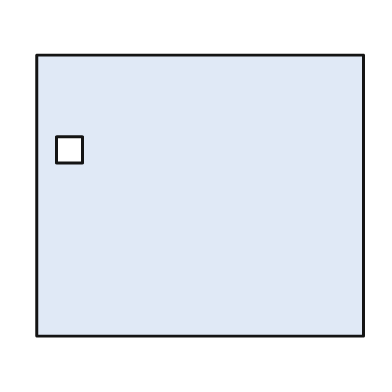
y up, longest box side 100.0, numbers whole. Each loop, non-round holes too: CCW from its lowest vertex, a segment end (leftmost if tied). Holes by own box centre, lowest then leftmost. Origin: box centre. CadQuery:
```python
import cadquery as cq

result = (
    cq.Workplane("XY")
    .moveTo(-50.0, -43.0)
    .lineTo(50.0, -43.0)
    .lineTo(50.0, 43.0)
    .lineTo(-50.0, 43.0)
    .close()
    .moveTo(-44.0, 10.0)
    .lineTo(-36.0, 10.0)
    .lineTo(-36.0, 18.0)
    .lineTo(-44.0, 18.0)
    .close()
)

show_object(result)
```